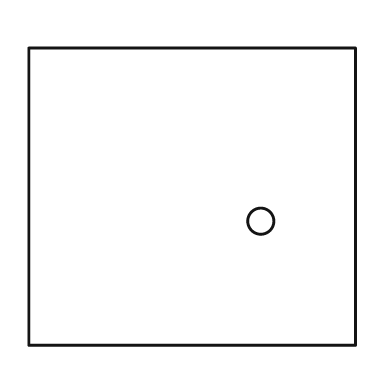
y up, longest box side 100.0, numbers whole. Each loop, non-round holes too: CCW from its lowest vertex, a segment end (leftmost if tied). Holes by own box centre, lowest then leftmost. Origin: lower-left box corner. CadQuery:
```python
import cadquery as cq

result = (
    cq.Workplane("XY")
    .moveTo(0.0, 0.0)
    .lineTo(100.0, 0.0)
    .lineTo(100.0, 91.0)
    .lineTo(0.0, 91.0)
    .close()
    .moveTo(71.0, 38.0)
    .circle(4.0)
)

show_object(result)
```